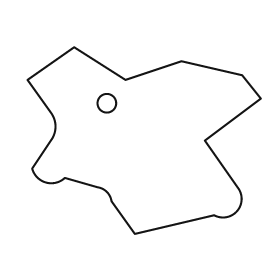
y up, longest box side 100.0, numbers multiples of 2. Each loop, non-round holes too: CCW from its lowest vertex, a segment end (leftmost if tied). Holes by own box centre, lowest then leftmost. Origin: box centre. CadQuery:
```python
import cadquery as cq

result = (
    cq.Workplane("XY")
    .moveTo(-4.0, -40.0)
    .lineTo(30.0, -32.0)
    .threePointArc((40.0, -30.0), (40.0, -20.0))
    .lineTo(26.0, 0.0)
    .lineTo(50.0, 18.0)
    .lineTo(42.0, 28.0)
    .lineTo(16.0, 34.0)
    .lineTo(-8.0, 26.0)
    .lineTo(-30.0, 40.0)
    .lineTo(-50.0, 26.0)
    .lineTo(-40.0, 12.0)
    .threePointArc((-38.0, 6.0), (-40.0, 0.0))
    .lineTo(-48.0, -12.0)
    .threePointArc((-42.0, -18.0), (-34.0, -16.0))
    .lineTo(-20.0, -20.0)
    .threePointArc((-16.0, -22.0), (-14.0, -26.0))
    .close()
    .moveTo(-16.0, 16.0)
    .circle(4.0)
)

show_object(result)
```